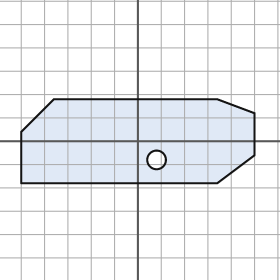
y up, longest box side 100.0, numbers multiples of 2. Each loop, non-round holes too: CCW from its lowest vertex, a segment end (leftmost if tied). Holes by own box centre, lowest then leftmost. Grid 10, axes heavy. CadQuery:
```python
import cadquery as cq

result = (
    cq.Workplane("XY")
    .moveTo(-50.0, -18.0)
    .lineTo(34.0, -18.0)
    .lineTo(50.0, -6.0)
    .lineTo(50.0, 12.0)
    .lineTo(34.0, 18.0)
    .lineTo(-36.0, 18.0)
    .lineTo(-50.0, 4.0)
    .close()
    .moveTo(8.0, -8.0)
    .circle(4.0)
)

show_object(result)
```